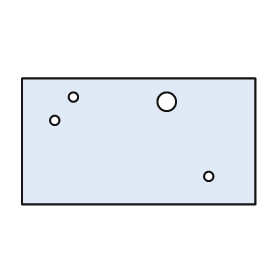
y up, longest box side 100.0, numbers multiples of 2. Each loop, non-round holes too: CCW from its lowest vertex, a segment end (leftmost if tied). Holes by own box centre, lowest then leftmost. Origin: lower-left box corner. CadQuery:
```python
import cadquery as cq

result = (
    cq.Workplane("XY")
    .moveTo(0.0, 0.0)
    .lineTo(100.0, 0.0)
    .lineTo(100.0, 54.0)
    .lineTo(0.0, 54.0)
    .close()
    .moveTo(80.0, 12.0)
    .circle(2.0)
    .moveTo(14.0, 36.0)
    .circle(2.0)
    .moveTo(62.0, 44.0)
    .circle(4.0)
    .moveTo(22.0, 46.0)
    .circle(2.0)
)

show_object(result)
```